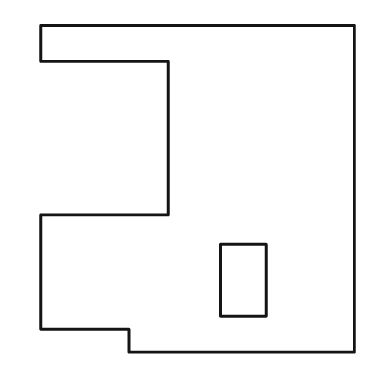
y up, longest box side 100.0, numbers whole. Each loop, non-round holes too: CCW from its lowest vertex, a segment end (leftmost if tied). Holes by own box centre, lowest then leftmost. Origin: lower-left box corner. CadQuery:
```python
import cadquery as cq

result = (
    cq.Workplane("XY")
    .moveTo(27.0, 0.0)
    .lineTo(96.0, 0.0)
    .lineTo(96.0, 100.0)
    .lineTo(0.0, 100.0)
    .lineTo(0.0, 89.0)
    .lineTo(39.0, 89.0)
    .lineTo(39.0, 42.0)
    .lineTo(0.0, 42.0)
    .lineTo(0.0, 7.0)
    .lineTo(27.0, 7.0)
    .close()
    .moveTo(55.0, 11.0)
    .lineTo(69.0, 11.0)
    .lineTo(69.0, 33.0)
    .lineTo(55.0, 33.0)
    .close()
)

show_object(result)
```